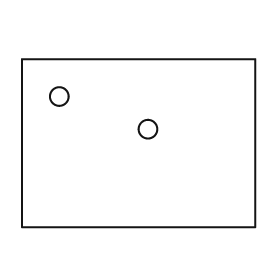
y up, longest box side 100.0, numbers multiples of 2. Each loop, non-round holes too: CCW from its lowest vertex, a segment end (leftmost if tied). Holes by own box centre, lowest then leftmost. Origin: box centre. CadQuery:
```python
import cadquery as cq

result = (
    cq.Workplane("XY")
    .moveTo(-50.0, -36.0)
    .lineTo(50.0, -36.0)
    .lineTo(50.0, 36.0)
    .lineTo(-50.0, 36.0)
    .close()
    .moveTo(4.0, 6.0)
    .circle(4.0)
    .moveTo(-34.0, 20.0)
    .circle(4.0)
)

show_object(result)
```